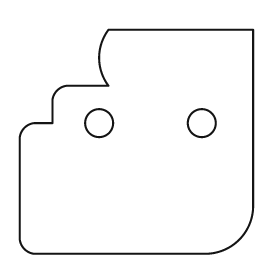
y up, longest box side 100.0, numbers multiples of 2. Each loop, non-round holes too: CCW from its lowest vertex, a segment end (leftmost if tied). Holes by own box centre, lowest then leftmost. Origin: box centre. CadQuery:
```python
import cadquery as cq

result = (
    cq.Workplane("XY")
    .moveTo(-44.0, -48.0)
    .lineTo(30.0, -48.0)
    .threePointArc((44.0, -42.0), (50.0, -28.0))
    .lineTo(50.0, 48.0)
    .lineTo(-12.0, 48.0)
    .threePointArc((-16.0, 36.0), (-12.0, 24.0))
    .lineTo(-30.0, 24.0)
    .threePointArc((-34.0, 22.0), (-36.0, 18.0))
    .lineTo(-36.0, 8.0)
    .lineTo(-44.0, 8.0)
    .threePointArc((-48.0, 6.0), (-50.0, 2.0))
    .lineTo(-50.0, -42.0)
    .threePointArc((-48.0, -46.0), (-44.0, -48.0))
    .close()
    .moveTo(-16.0, 8.0)
    .circle(6.0)
    .moveTo(28.0, 8.0)
    .circle(6.0)
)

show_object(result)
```